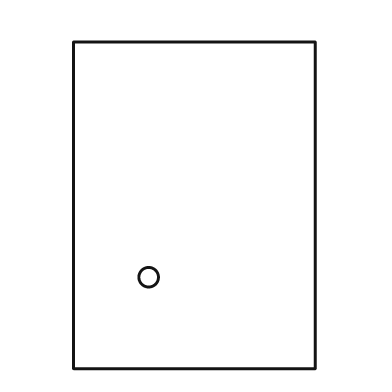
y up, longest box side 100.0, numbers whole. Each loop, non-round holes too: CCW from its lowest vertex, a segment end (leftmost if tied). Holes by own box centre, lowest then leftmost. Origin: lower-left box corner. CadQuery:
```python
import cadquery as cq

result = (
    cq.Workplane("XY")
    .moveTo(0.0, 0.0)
    .lineTo(74.0, 0.0)
    .lineTo(74.0, 100.0)
    .lineTo(0.0, 100.0)
    .close()
    .moveTo(23.0, 28.0)
    .circle(3.0)
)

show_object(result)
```